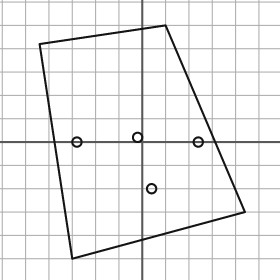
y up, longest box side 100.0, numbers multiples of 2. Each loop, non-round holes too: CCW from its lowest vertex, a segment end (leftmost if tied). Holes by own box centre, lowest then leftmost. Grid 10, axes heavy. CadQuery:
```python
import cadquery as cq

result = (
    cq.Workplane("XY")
    .moveTo(-30.0, -50.0)
    .lineTo(44.0, -30.0)
    .lineTo(10.0, 50.0)
    .lineTo(-44.0, 42.0)
    .close()
    .moveTo(4.0, -20.0)
    .circle(2.0)
    .moveTo(-28.0, 0.0)
    .circle(2.0)
    .moveTo(24.0, 0.0)
    .circle(2.0)
    .moveTo(-2.0, 2.0)
    .circle(2.0)
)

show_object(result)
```